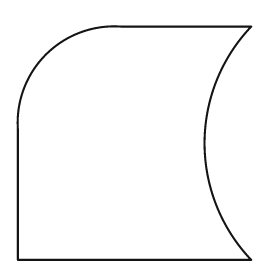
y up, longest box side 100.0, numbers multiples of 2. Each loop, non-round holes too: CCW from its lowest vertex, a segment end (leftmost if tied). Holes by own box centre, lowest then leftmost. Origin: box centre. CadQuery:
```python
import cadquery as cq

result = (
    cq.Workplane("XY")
    .moveTo(-50.0, -50.0)
    .lineTo(50.0, -50.0)
    .threePointArc((30.0, 0.0), (50.0, 50.0))
    .lineTo(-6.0, 50.0)
    .threePointArc((-38.0, 38.0), (-50.0, 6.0))
    .close()
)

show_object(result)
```